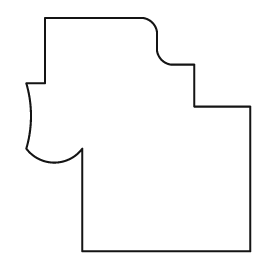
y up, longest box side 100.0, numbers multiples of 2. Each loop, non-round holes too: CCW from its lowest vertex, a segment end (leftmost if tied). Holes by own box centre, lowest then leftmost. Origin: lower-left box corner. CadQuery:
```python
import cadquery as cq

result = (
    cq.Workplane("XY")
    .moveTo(24.0, 0.0)
    .lineTo(96.0, 0.0)
    .lineTo(96.0, 62.0)
    .lineTo(72.0, 62.0)
    .lineTo(72.0, 80.0)
    .lineTo(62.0, 80.0)
    .threePointArc((58.0, 82.0), (56.0, 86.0))
    .lineTo(56.0, 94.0)
    .threePointArc((54.0, 98.0), (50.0, 100.0))
    .lineTo(8.0, 100.0)
    .lineTo(8.0, 72.0)
    .lineTo(0.0, 72.0)
    .threePointArc((2.0, 58.0), (0.0, 44.0))
    .threePointArc((12.0, 38.0), (24.0, 44.0))
    .close()
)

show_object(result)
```